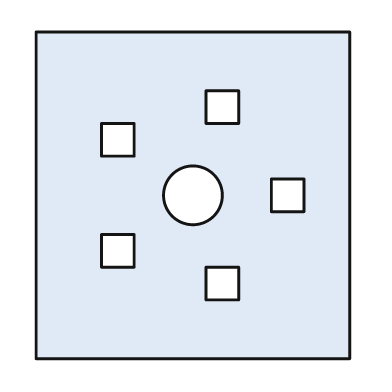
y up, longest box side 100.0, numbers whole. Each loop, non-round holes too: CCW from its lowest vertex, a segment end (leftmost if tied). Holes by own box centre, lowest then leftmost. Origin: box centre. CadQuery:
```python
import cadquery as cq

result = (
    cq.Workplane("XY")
    .moveTo(-48.0, -50.0)
    .lineTo(48.0, -50.0)
    .lineTo(48.0, 50.0)
    .lineTo(-48.0, 50.0)
    .close()
    .moveTo(4.0, -32.0)
    .lineTo(14.0, -32.0)
    .lineTo(14.0, -22.0)
    .lineTo(4.0, -22.0)
    .close()
    .moveTo(-28.0, -22.0)
    .lineTo(-18.0, -22.0)
    .lineTo(-18.0, -12.0)
    .lineTo(-28.0, -12.0)
    .close()
    .moveTo(0.0, 0.0)
    .circle(9.0)
    .moveTo(24.0, -5.0)
    .lineTo(34.0, -5.0)
    .lineTo(34.0, 5.0)
    .lineTo(24.0, 5.0)
    .close()
    .moveTo(-28.0, 12.0)
    .lineTo(-18.0, 12.0)
    .lineTo(-18.0, 22.0)
    .lineTo(-28.0, 22.0)
    .close()
    .moveTo(4.0, 22.0)
    .lineTo(14.0, 22.0)
    .lineTo(14.0, 32.0)
    .lineTo(4.0, 32.0)
    .close()
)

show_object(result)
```